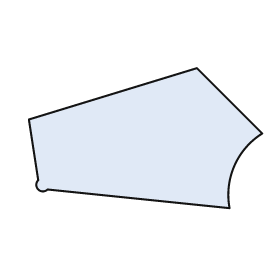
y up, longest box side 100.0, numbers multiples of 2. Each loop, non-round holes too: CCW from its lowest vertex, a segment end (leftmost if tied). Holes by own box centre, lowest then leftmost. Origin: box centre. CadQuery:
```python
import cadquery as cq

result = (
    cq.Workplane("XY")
    .moveTo(36.0, -30.0)
    .threePointArc((38.0, -12.0), (50.0, 2.0))
    .lineTo(22.0, 30.0)
    .lineTo(-50.0, 8.0)
    .lineTo(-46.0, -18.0)
    .threePointArc((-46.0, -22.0), (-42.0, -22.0))
    .close()
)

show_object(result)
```